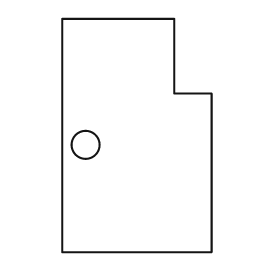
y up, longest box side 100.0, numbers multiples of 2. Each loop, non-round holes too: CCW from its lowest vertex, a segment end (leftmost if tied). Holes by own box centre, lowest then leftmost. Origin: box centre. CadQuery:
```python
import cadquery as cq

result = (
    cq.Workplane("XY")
    .moveTo(-32.0, -50.0)
    .lineTo(32.0, -50.0)
    .lineTo(32.0, 18.0)
    .lineTo(16.0, 18.0)
    .lineTo(16.0, 50.0)
    .lineTo(-32.0, 50.0)
    .close()
    .moveTo(-22.0, -4.0)
    .circle(6.0)
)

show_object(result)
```